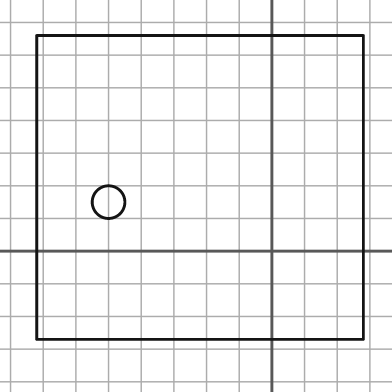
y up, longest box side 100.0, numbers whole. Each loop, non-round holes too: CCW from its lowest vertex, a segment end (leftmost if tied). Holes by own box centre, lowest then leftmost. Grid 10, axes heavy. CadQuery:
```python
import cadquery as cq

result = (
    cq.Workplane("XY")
    .moveTo(-72.0, -27.0)
    .lineTo(28.0, -27.0)
    .lineTo(28.0, 66.0)
    .lineTo(-72.0, 66.0)
    .close()
    .moveTo(-50.0, 15.0)
    .circle(5.0)
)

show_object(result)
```